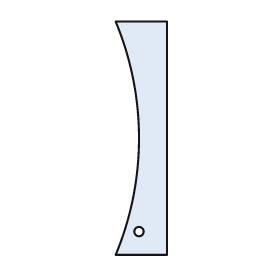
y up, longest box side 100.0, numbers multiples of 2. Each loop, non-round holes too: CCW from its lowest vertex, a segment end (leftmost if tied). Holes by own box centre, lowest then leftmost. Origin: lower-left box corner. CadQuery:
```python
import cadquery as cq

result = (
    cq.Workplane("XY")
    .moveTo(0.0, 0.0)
    .lineTo(22.0, 0.0)
    .lineTo(22.0, 100.0)
    .lineTo(0.0, 100.0)
    .threePointArc((10.0, 50.0), (0.0, 0.0))
    .close()
    .moveTo(10.0, 10.0)
    .circle(2.0)
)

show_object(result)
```